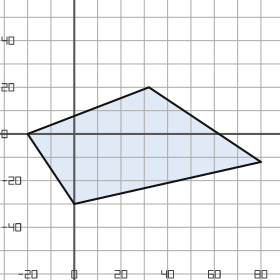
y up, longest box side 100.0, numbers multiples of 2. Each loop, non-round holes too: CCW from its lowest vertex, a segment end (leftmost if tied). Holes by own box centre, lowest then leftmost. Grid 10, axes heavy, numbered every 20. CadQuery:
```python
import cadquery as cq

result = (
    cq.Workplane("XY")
    .moveTo(0.0, -30.0)
    .lineTo(80.0, -12.0)
    .lineTo(32.0, 20.0)
    .lineTo(-20.0, 0.0)
    .close()
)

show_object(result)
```